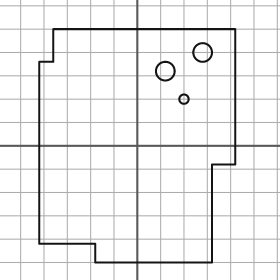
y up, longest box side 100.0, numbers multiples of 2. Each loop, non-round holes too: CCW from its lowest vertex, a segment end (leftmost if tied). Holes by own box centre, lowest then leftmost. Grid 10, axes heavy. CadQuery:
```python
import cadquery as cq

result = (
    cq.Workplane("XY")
    .moveTo(-18.0, -50.0)
    .lineTo(32.0, -50.0)
    .lineTo(32.0, -8.0)
    .lineTo(42.0, -8.0)
    .lineTo(42.0, 50.0)
    .lineTo(-36.0, 50.0)
    .lineTo(-36.0, 36.0)
    .lineTo(-42.0, 36.0)
    .lineTo(-42.0, -42.0)
    .lineTo(-18.0, -42.0)
    .close()
    .moveTo(20.0, 20.0)
    .circle(2.0)
    .moveTo(12.0, 32.0)
    .circle(4.0)
    .moveTo(28.0, 40.0)
    .circle(4.0)
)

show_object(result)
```